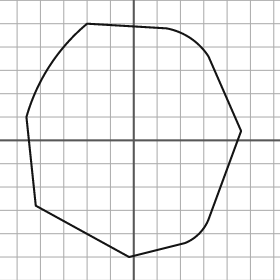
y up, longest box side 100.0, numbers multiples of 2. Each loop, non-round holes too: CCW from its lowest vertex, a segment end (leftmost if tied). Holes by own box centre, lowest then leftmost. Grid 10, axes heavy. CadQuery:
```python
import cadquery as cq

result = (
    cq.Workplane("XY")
    .moveTo(-2.0, -50.0)
    .lineTo(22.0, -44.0)
    .threePointArc((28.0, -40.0), (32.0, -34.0))
    .lineTo(46.0, 4.0)
    .lineTo(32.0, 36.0)
    .threePointArc((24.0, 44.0), (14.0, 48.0))
    .lineTo(-20.0, 50.0)
    .threePointArc((-36.0, 32.0), (-46.0, 10.0))
    .lineTo(-42.0, -28.0)
    .close()
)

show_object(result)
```